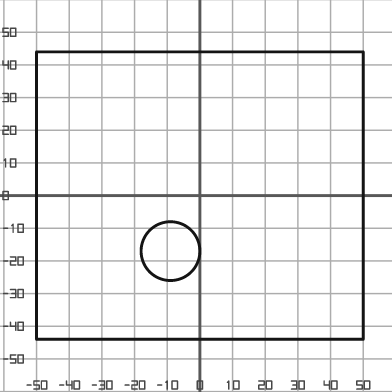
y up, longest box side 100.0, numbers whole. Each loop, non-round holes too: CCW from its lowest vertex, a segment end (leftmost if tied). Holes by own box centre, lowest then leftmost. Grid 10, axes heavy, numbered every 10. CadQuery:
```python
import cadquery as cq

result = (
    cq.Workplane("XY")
    .moveTo(-50.0, -44.0)
    .lineTo(50.0, -44.0)
    .lineTo(50.0, 44.0)
    .lineTo(-50.0, 44.0)
    .close()
    .moveTo(-9.0, -17.0)
    .circle(9.0)
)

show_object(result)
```